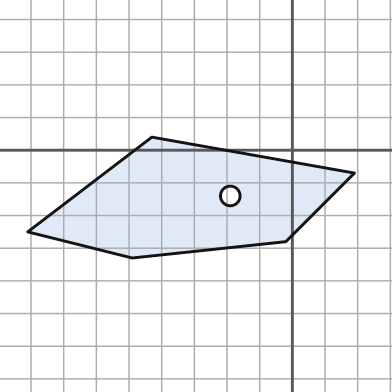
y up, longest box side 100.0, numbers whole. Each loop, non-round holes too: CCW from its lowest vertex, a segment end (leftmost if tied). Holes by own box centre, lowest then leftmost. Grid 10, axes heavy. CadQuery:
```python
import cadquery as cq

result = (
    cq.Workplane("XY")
    .moveTo(-49.0, -33.0)
    .lineTo(-2.0, -28.0)
    .lineTo(19.0, -7.0)
    .lineTo(-43.0, 4.0)
    .lineTo(-81.0, -25.0)
    .close()
    .moveTo(-19.0, -14.0)
    .circle(3.0)
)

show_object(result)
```